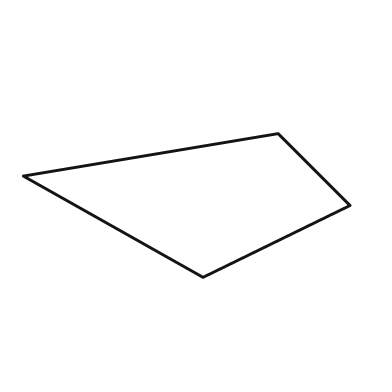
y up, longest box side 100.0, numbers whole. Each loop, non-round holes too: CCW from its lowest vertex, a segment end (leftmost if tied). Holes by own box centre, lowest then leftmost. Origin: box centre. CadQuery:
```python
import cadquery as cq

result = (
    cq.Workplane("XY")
    .moveTo(5.0, -22.0)
    .lineTo(50.0, 0.0)
    .lineTo(28.0, 22.0)
    .lineTo(-50.0, 9.0)
    .close()
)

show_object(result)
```